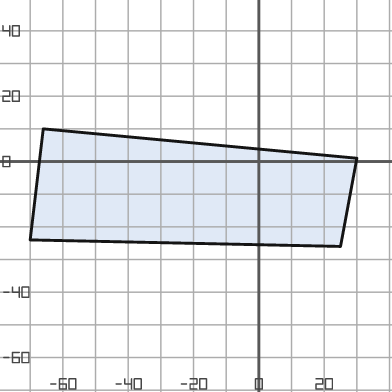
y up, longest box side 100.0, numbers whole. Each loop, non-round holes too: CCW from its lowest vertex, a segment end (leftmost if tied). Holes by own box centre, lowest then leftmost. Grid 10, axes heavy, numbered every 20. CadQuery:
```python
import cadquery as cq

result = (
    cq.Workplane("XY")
    .moveTo(25.0, -26.0)
    .lineTo(30.0, 1.0)
    .lineTo(-66.0, 10.0)
    .lineTo(-70.0, -24.0)
    .close()
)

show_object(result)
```